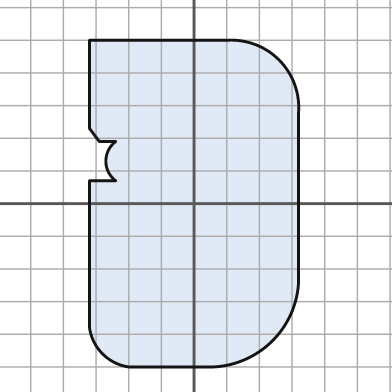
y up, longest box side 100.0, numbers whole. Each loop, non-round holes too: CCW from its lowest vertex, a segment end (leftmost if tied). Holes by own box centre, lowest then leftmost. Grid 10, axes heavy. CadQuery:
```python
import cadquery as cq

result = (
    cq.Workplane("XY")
    .moveTo(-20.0, -50.0)
    .lineTo(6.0, -50.0)
    .threePointArc((24.0, -42.0), (32.0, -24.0))
    .lineTo(32.0, 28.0)
    .threePointArc((26.0, 44.0), (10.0, 50.0))
    .lineTo(-32.0, 50.0)
    .lineTo(-32.0, 23.0)
    .lineTo(-29.0, 19.0)
    .lineTo(-24.0, 19.0)
    .threePointArc((-27.0, 13.0), (-24.0, 7.0))
    .lineTo(-32.0, 7.0)
    .lineTo(-32.0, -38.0)
    .threePointArc((-28.0, -46.0), (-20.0, -50.0))
    .close()
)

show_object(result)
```